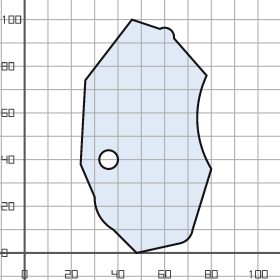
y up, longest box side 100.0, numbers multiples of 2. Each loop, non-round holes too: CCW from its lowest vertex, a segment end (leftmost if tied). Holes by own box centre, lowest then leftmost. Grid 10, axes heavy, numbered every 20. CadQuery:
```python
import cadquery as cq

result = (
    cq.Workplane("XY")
    .moveTo(48.0, 0.0)
    .lineTo(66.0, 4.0)
    .threePointArc((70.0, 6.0), (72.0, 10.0))
    .lineTo(80.0, 36.0)
    .threePointArc((74.0, 56.0), (78.0, 76.0))
    .lineTo(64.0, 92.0)
    .threePointArc((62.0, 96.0), (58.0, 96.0))
    .lineTo(46.0, 100.0)
    .lineTo(26.0, 74.0)
    .lineTo(24.0, 38.0)
    .lineTo(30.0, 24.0)
    .threePointArc((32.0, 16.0), (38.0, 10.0))
    .close()
    .moveTo(36.0, 40.0)
    .circle(4.0)
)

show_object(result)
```